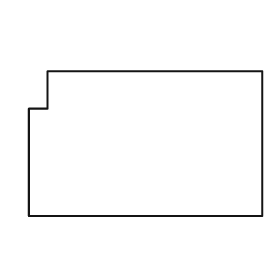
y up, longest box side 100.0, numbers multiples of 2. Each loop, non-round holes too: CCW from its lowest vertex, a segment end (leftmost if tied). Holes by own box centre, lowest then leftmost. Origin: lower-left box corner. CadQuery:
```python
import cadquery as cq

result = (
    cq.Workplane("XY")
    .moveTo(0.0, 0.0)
    .lineTo(100.0, 0.0)
    .lineTo(100.0, 62.0)
    .lineTo(8.0, 62.0)
    .lineTo(8.0, 46.0)
    .lineTo(0.0, 46.0)
    .close()
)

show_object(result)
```